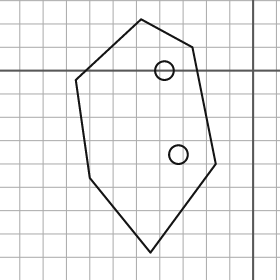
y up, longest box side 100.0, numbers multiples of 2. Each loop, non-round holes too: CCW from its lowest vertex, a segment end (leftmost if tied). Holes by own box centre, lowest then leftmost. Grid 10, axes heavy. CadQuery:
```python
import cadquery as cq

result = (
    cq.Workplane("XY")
    .moveTo(-44.0, -78.0)
    .lineTo(-16.0, -40.0)
    .lineTo(-26.0, 10.0)
    .lineTo(-48.0, 22.0)
    .lineTo(-76.0, -4.0)
    .lineTo(-70.0, -46.0)
    .close()
    .moveTo(-32.0, -36.0)
    .circle(4.0)
    .moveTo(-38.0, 0.0)
    .circle(4.0)
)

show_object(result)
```